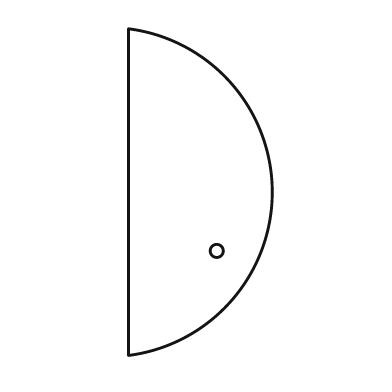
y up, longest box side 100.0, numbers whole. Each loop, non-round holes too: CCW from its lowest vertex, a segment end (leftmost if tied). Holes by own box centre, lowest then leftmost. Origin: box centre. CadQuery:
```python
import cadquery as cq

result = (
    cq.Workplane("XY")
    .moveTo(-22.0, -50.0)
    .threePointArc((22.0, 0.0), (-22.0, 50.0))
    .close()
    .moveTo(5.0, -18.0)
    .circle(2.0)
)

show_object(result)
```